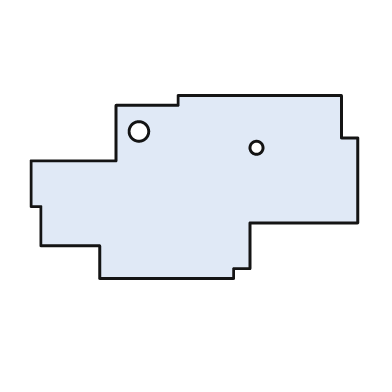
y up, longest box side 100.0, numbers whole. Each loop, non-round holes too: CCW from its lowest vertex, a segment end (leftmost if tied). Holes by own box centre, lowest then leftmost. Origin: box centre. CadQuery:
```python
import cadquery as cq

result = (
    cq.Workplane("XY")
    .moveTo(-29.0, -28.0)
    .lineTo(12.0, -28.0)
    .lineTo(12.0, -25.0)
    .lineTo(17.0, -25.0)
    .lineTo(17.0, -11.0)
    .lineTo(50.0, -11.0)
    .lineTo(50.0, 15.0)
    .lineTo(45.0, 15.0)
    .lineTo(45.0, 28.0)
    .lineTo(-5.0, 28.0)
    .lineTo(-5.0, 25.0)
    .lineTo(-24.0, 25.0)
    .lineTo(-24.0, 8.0)
    .lineTo(-50.0, 8.0)
    .lineTo(-50.0, -6.0)
    .lineTo(-47.0, -6.0)
    .lineTo(-47.0, -18.0)
    .lineTo(-29.0, -18.0)
    .close()
    .moveTo(19.0, 12.0)
    .circle(2.0)
    .moveTo(-17.0, 17.0)
    .circle(3.0)
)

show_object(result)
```